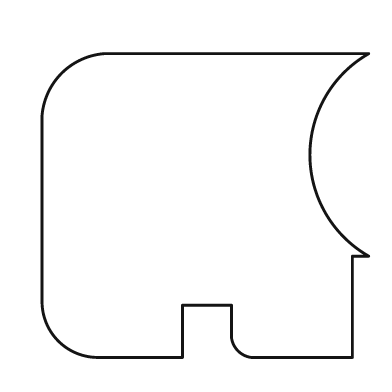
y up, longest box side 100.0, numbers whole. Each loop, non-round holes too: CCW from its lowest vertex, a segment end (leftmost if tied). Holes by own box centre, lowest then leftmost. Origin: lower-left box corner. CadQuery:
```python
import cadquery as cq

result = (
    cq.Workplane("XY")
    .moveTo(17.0, 0.0)
    .lineTo(43.0, 0.0)
    .lineTo(43.0, 16.0)
    .lineTo(58.0, 16.0)
    .lineTo(58.0, 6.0)
    .threePointArc((60.0, 2.0), (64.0, 0.0))
    .lineTo(95.0, 0.0)
    .lineTo(95.0, 31.0)
    .lineTo(100.0, 31.0)
    .threePointArc((82.0, 62.0), (100.0, 93.0))
    .lineTo(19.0, 93.0)
    .threePointArc((6.0, 87.0), (0.0, 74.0))
    .lineTo(0.0, 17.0)
    .threePointArc((5.0, 5.0), (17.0, 0.0))
    .close()
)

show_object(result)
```